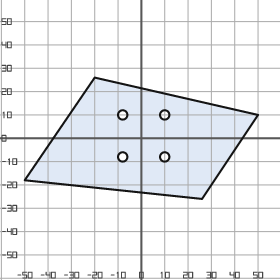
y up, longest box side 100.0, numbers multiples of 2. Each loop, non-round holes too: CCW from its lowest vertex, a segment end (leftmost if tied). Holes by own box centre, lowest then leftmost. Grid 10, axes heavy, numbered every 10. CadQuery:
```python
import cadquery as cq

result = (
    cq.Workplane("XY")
    .moveTo(26.0, -26.0)
    .lineTo(50.0, 10.0)
    .lineTo(-20.0, 26.0)
    .lineTo(-50.0, -18.0)
    .close()
    .moveTo(-8.0, -8.0)
    .circle(2.0)
    .moveTo(10.0, -8.0)
    .circle(2.0)
    .moveTo(-8.0, 10.0)
    .circle(2.0)
    .moveTo(10.0, 10.0)
    .circle(2.0)
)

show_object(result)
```